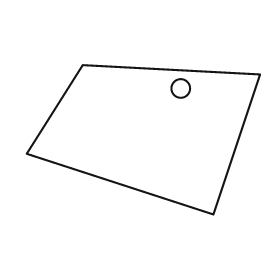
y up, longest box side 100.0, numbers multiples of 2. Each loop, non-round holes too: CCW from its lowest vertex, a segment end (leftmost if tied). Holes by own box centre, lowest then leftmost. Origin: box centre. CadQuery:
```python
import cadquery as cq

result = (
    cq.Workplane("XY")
    .moveTo(30.0, -32.0)
    .lineTo(50.0, 28.0)
    .lineTo(-26.0, 32.0)
    .lineTo(-50.0, -6.0)
    .close()
    .moveTo(16.0, 22.0)
    .circle(4.0)
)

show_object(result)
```